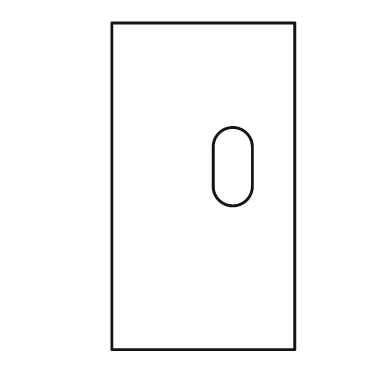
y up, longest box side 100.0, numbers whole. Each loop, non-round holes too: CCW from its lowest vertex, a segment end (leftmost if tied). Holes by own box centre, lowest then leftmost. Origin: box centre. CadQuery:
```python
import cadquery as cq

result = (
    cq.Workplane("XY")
    .moveTo(-28.0, -50.0)
    .lineTo(28.0, -50.0)
    .lineTo(28.0, 50.0)
    .lineTo(-28.0, 50.0)
    .close()
    .moveTo(3.0, 0.0)
    .threePointArc((9.0, -6.0), (15.0, 0.0))
    .lineTo(15.0, 12.0)
    .threePointArc((9.0, 18.0), (3.0, 12.0))
    .close()
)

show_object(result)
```